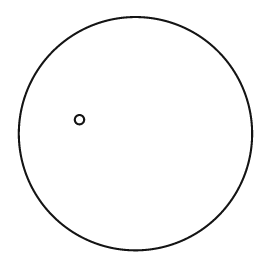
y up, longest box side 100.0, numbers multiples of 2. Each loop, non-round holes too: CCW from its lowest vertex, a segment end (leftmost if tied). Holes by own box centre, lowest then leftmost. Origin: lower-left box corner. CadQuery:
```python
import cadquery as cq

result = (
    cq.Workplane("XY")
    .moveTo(50.0, 50.0)
    .circle(50.0)
    .moveTo(26.0, 56.0)
    .circle(2.0)
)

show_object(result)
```